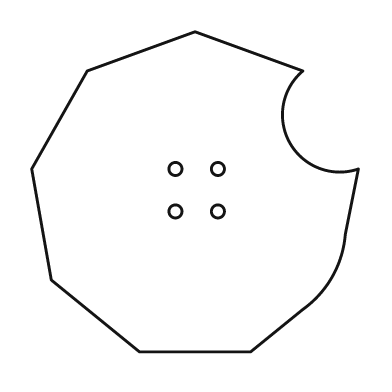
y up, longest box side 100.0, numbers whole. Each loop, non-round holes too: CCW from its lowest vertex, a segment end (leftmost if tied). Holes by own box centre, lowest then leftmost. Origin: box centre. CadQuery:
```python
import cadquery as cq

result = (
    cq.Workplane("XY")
    .moveTo(-17.0, -49.0)
    .lineTo(17.0, -49.0)
    .lineTo(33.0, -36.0)
    .threePointArc((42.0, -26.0), (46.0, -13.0))
    .lineTo(50.0, 7.0)
    .threePointArc((29.0, 15.0), (33.0, 37.0))
    .lineTo(0.0, 49.0)
    .lineTo(-33.0, 37.0)
    .lineTo(-50.0, 7.0)
    .lineTo(-44.0, -27.0)
    .close()
    .moveTo(-6.0, -6.0)
    .circle(2.0)
    .moveTo(7.0, -6.0)
    .circle(2.0)
    .moveTo(-6.0, 7.0)
    .circle(2.0)
    .moveTo(7.0, 7.0)
    .circle(2.0)
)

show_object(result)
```